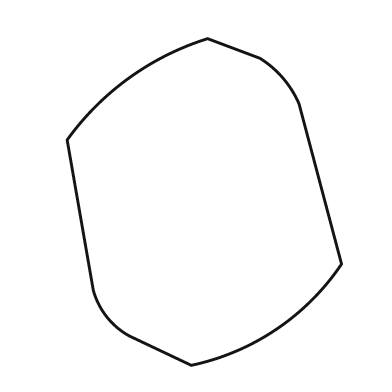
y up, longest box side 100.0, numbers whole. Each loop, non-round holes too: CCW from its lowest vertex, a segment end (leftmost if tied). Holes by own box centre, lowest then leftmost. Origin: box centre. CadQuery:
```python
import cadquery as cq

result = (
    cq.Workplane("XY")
    .moveTo(-4.0, -50.0)
    .threePointArc((22.0, -39.0), (42.0, -19.0))
    .lineTo(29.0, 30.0)
    .threePointArc((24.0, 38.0), (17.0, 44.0))
    .lineTo(1.0, 50.0)
    .threePointArc((-23.0, 38.0), (-42.0, 19.0))
    .lineTo(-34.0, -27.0)
    .threePointArc((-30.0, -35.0), (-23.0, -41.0))
    .close()
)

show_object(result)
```